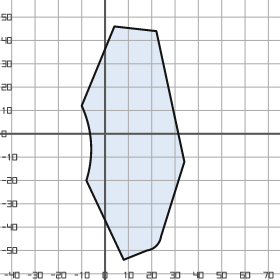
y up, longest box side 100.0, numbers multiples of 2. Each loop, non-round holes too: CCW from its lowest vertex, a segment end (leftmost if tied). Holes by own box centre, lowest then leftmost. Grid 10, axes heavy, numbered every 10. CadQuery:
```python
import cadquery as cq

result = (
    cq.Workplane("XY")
    .moveTo(8.0, -54.0)
    .lineTo(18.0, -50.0)
    .threePointArc((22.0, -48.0), (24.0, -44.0))
    .lineTo(34.0, -12.0)
    .lineTo(22.0, 44.0)
    .lineTo(4.0, 46.0)
    .lineTo(-10.0, 12.0)
    .threePointArc((-6.0, -4.0), (-8.0, -20.0))
    .close()
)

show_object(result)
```